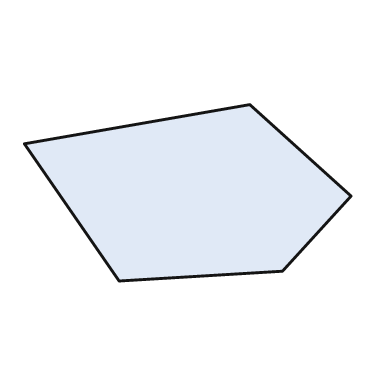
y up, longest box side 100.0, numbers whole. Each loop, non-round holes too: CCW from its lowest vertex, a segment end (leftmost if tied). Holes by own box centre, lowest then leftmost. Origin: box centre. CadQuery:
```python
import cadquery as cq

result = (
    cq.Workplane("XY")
    .moveTo(-21.0, -27.0)
    .lineTo(29.0, -24.0)
    .lineTo(50.0, -1.0)
    .lineTo(19.0, 27.0)
    .lineTo(-50.0, 15.0)
    .close()
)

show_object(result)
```